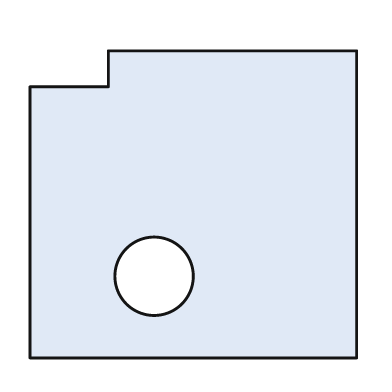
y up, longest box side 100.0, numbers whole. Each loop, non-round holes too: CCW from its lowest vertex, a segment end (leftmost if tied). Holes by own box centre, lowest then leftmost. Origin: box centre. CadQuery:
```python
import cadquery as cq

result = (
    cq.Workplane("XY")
    .moveTo(-50.0, -47.0)
    .lineTo(50.0, -47.0)
    .lineTo(50.0, 47.0)
    .lineTo(-26.0, 47.0)
    .lineTo(-26.0, 36.0)
    .lineTo(-50.0, 36.0)
    .close()
    .moveTo(-12.0, -22.0)
    .circle(12.0)
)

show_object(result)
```